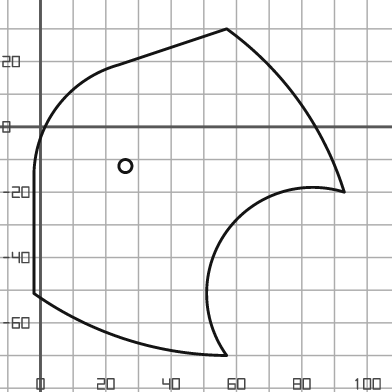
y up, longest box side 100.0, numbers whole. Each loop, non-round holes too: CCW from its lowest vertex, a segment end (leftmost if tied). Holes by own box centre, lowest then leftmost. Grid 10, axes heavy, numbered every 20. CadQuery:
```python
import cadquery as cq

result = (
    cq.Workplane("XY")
    .moveTo(57.0, -70.0)
    .threePointArc((57.0, -32.0), (93.0, -20.0))
    .threePointArc((79.0, 8.0), (57.0, 30.0))
    .lineTo(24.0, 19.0)
    .threePointArc((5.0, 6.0), (-2.0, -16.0))
    .lineTo(-2.0, -51.0)
    .threePointArc((26.0, -65.0), (57.0, -70.0))
    .close()
    .moveTo(26.0, -12.0)
    .circle(2.0)
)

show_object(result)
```